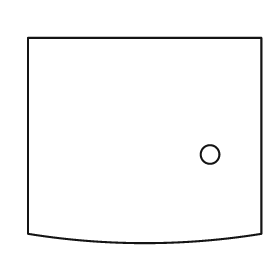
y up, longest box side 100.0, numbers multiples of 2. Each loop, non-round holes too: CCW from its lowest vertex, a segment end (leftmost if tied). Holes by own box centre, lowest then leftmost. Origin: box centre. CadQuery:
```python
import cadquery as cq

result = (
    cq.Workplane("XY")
    .moveTo(-50.0, -40.0)
    .threePointArc((0.0, -44.0), (50.0, -40.0))
    .lineTo(50.0, 44.0)
    .lineTo(-50.0, 44.0)
    .close()
    .moveTo(28.0, -6.0)
    .circle(4.0)
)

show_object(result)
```